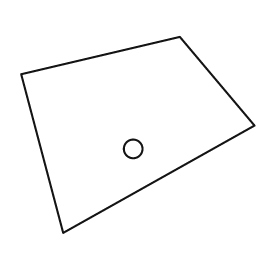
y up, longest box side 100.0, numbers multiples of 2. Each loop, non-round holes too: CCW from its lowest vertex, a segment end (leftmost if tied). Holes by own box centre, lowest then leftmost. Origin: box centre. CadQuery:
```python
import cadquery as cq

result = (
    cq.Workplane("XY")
    .moveTo(-32.0, -42.0)
    .lineTo(50.0, 4.0)
    .lineTo(18.0, 42.0)
    .lineTo(-50.0, 26.0)
    .close()
    .moveTo(-2.0, -6.0)
    .circle(4.0)
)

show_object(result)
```